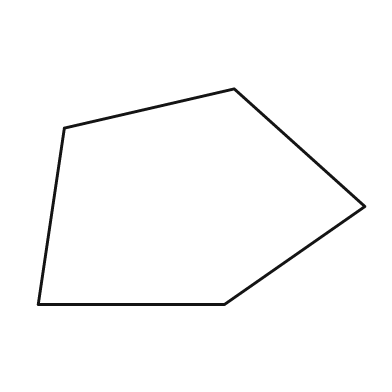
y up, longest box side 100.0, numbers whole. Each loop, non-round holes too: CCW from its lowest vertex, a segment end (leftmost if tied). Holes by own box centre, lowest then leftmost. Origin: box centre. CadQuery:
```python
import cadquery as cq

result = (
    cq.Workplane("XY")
    .moveTo(-50.0, -33.0)
    .lineTo(7.0, -33.0)
    .lineTo(50.0, -3.0)
    .lineTo(10.0, 33.0)
    .lineTo(-42.0, 21.0)
    .close()
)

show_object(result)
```